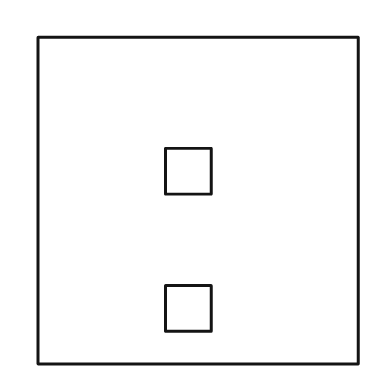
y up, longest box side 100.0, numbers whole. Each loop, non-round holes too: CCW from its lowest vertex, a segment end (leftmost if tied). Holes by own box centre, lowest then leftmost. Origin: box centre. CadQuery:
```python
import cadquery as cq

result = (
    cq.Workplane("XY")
    .moveTo(-49.0, -50.0)
    .lineTo(49.0, -50.0)
    .lineTo(49.0, 50.0)
    .lineTo(-49.0, 50.0)
    .close()
    .moveTo(-10.0, -40.0)
    .lineTo(4.0, -40.0)
    .lineTo(4.0, -26.0)
    .lineTo(-10.0, -26.0)
    .close()
    .moveTo(-10.0, 2.0)
    .lineTo(4.0, 2.0)
    .lineTo(4.0, 16.0)
    .lineTo(-10.0, 16.0)
    .close()
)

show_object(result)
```